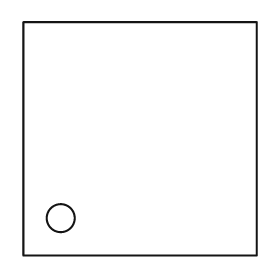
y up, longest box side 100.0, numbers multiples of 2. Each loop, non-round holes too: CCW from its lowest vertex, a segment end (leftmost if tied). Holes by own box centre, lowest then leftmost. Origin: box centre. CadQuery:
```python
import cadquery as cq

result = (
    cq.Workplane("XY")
    .moveTo(-50.0, -50.0)
    .lineTo(50.0, -50.0)
    .lineTo(50.0, 50.0)
    .lineTo(-50.0, 50.0)
    .close()
    .moveTo(-34.0, -34.0)
    .circle(6.0)
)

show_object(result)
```